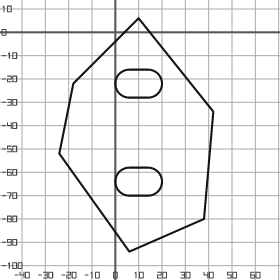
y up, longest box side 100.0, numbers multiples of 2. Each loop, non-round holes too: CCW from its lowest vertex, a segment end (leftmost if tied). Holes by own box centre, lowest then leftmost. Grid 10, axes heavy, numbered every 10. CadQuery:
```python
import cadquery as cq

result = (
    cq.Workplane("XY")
    .moveTo(6.0, -94.0)
    .lineTo(38.0, -80.0)
    .lineTo(42.0, -34.0)
    .lineTo(10.0, 6.0)
    .lineTo(-18.0, -22.0)
    .lineTo(-24.0, -52.0)
    .close()
    .moveTo(6.0, -70.0)
    .lineTo(14.0, -70.0)
    .threePointArc((20.0, -64.0), (14.0, -58.0))
    .lineTo(6.0, -58.0)
    .threePointArc((0.0, -64.0), (6.0, -70.0))
    .close()
    .moveTo(6.0, -28.0)
    .lineTo(14.0, -28.0)
    .threePointArc((20.0, -22.0), (14.0, -16.0))
    .lineTo(6.0, -16.0)
    .threePointArc((0.0, -22.0), (6.0, -28.0))
    .close()
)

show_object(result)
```